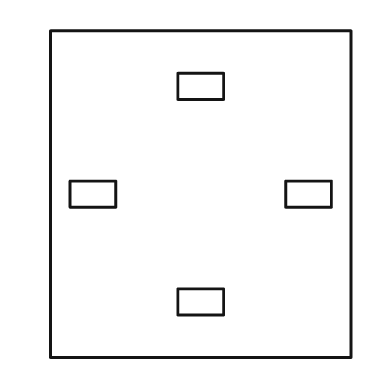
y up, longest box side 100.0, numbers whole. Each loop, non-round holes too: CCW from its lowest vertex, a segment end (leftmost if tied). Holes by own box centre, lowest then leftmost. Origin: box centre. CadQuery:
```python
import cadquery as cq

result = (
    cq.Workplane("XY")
    .moveTo(-46.0, -50.0)
    .lineTo(46.0, -50.0)
    .lineTo(46.0, 50.0)
    .lineTo(-46.0, 50.0)
    .close()
    .moveTo(-7.0, -37.0)
    .lineTo(7.0, -37.0)
    .lineTo(7.0, -29.0)
    .lineTo(-7.0, -29.0)
    .close()
    .moveTo(-40.0, -4.0)
    .lineTo(-26.0, -4.0)
    .lineTo(-26.0, 4.0)
    .lineTo(-40.0, 4.0)
    .close()
    .moveTo(26.0, -4.0)
    .lineTo(40.0, -4.0)
    .lineTo(40.0, 4.0)
    .lineTo(26.0, 4.0)
    .close()
    .moveTo(-7.0, 29.0)
    .lineTo(7.0, 29.0)
    .lineTo(7.0, 37.0)
    .lineTo(-7.0, 37.0)
    .close()
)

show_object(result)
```